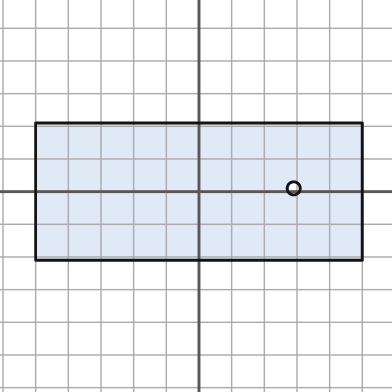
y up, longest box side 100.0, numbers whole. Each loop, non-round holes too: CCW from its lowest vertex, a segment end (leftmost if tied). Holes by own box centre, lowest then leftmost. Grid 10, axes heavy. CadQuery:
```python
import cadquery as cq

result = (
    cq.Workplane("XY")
    .moveTo(-50.0, -21.0)
    .lineTo(50.0, -21.0)
    .lineTo(50.0, 21.0)
    .lineTo(-50.0, 21.0)
    .close()
    .moveTo(29.0, 1.0)
    .circle(2.0)
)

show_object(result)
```